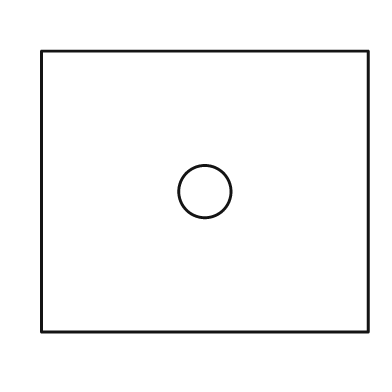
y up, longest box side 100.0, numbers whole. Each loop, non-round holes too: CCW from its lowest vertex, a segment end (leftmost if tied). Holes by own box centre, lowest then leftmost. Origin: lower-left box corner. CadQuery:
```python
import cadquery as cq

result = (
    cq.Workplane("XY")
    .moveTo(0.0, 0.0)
    .lineTo(100.0, 0.0)
    .lineTo(100.0, 86.0)
    .lineTo(0.0, 86.0)
    .close()
    .moveTo(50.0, 43.0)
    .circle(8.0)
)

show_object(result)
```